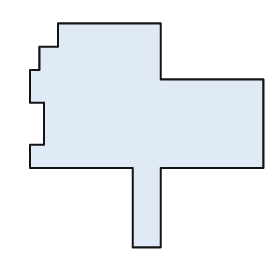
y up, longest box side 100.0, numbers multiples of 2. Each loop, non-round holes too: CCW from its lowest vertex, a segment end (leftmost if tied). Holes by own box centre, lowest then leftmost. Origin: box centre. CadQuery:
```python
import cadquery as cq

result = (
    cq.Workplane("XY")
    .moveTo(-6.0, -48.0)
    .lineTo(6.0, -48.0)
    .lineTo(6.0, -14.0)
    .lineTo(50.0, -14.0)
    .lineTo(50.0, 24.0)
    .lineTo(6.0, 24.0)
    .lineTo(6.0, 48.0)
    .lineTo(-38.0, 48.0)
    .lineTo(-38.0, 38.0)
    .lineTo(-46.0, 38.0)
    .lineTo(-46.0, 28.0)
    .lineTo(-50.0, 28.0)
    .lineTo(-50.0, 14.0)
    .lineTo(-44.0, 14.0)
    .lineTo(-44.0, -4.0)
    .lineTo(-50.0, -4.0)
    .lineTo(-50.0, -14.0)
    .lineTo(-6.0, -14.0)
    .close()
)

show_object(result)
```